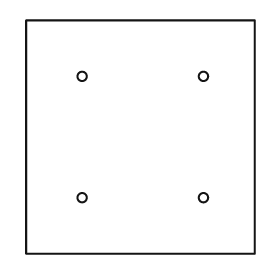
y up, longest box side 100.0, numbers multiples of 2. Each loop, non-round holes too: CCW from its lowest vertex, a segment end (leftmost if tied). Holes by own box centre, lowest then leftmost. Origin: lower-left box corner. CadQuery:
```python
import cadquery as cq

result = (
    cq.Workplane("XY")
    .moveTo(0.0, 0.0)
    .lineTo(98.0, 0.0)
    .lineTo(98.0, 100.0)
    .lineTo(0.0, 100.0)
    .close()
    .moveTo(24.0, 24.0)
    .circle(2.0)
    .moveTo(76.0, 24.0)
    .circle(2.0)
    .moveTo(24.0, 76.0)
    .circle(2.0)
    .moveTo(76.0, 76.0)
    .circle(2.0)
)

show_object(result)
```